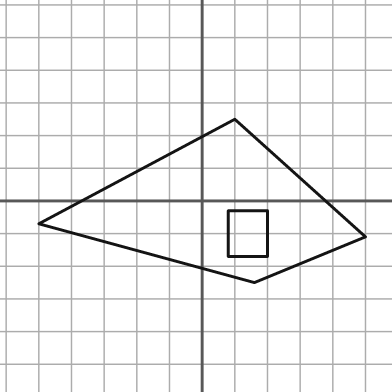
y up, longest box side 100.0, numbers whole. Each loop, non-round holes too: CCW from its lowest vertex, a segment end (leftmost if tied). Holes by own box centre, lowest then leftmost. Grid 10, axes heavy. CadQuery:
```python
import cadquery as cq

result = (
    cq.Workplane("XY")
    .moveTo(16.0, -25.0)
    .lineTo(50.0, -11.0)
    .lineTo(10.0, 25.0)
    .lineTo(-50.0, -7.0)
    .close()
    .moveTo(8.0, -17.0)
    .lineTo(20.0, -17.0)
    .lineTo(20.0, -3.0)
    .lineTo(8.0, -3.0)
    .close()
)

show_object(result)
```